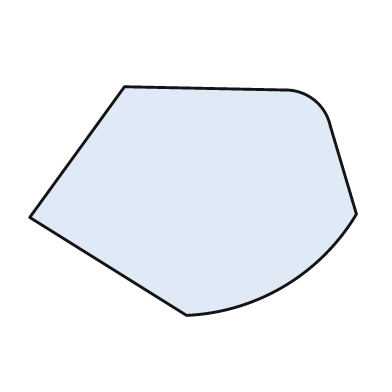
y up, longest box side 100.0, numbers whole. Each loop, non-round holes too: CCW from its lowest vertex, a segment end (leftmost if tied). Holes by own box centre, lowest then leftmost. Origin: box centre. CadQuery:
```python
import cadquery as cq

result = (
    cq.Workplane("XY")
    .moveTo(-2.0, -35.0)
    .threePointArc((28.0, -26.0), (50.0, -4.0))
    .lineTo(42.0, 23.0)
    .threePointArc((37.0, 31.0), (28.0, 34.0))
    .lineTo(-21.0, 35.0)
    .lineTo(-50.0, -5.0)
    .close()
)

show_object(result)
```